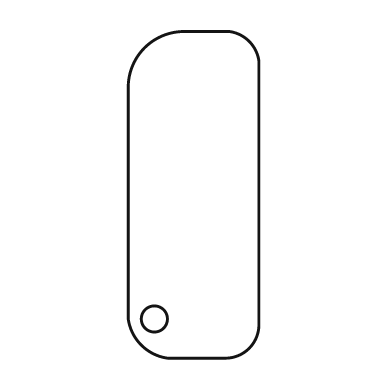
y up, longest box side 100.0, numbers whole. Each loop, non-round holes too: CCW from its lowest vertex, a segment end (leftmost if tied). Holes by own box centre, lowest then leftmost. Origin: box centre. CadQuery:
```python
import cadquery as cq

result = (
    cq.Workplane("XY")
    .moveTo(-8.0, -50.0)
    .lineTo(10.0, -50.0)
    .threePointArc((17.0, -47.0), (20.0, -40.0))
    .lineTo(20.0, 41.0)
    .threePointArc((17.0, 47.0), (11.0, 50.0))
    .lineTo(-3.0, 50.0)
    .threePointArc((-15.0, 45.0), (-20.0, 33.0))
    .lineTo(-20.0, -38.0)
    .threePointArc((-16.0, -46.0), (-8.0, -50.0))
    .close()
    .moveTo(-12.0, -38.0)
    .circle(4.0)
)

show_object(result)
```